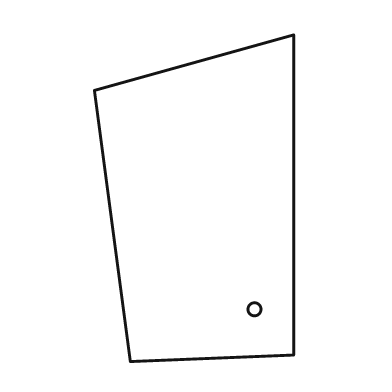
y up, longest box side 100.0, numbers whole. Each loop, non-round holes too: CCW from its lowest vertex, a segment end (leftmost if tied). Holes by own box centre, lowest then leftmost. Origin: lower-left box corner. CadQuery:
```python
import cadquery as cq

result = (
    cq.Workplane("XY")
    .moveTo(11.0, 0.0)
    .lineTo(61.0, 2.0)
    .lineTo(61.0, 100.0)
    .lineTo(0.0, 83.0)
    .close()
    .moveTo(49.0, 16.0)
    .circle(2.0)
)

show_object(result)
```